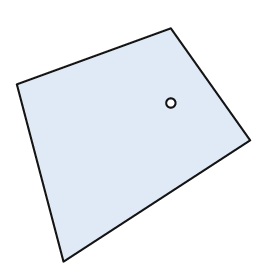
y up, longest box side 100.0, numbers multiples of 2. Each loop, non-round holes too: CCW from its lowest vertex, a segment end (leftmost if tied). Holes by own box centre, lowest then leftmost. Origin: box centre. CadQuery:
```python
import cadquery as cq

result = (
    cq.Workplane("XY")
    .moveTo(-30.0, -50.0)
    .lineTo(50.0, 2.0)
    .lineTo(16.0, 50.0)
    .lineTo(-50.0, 26.0)
    .close()
    .moveTo(16.0, 18.0)
    .circle(2.0)
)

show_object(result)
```